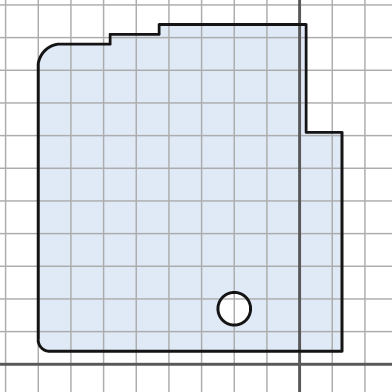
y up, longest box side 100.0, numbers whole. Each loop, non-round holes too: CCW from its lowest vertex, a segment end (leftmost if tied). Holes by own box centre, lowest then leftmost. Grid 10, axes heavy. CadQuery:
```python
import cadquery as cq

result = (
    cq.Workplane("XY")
    .moveTo(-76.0, 4.0)
    .lineTo(13.0, 4.0)
    .lineTo(13.0, 71.0)
    .lineTo(2.0, 71.0)
    .lineTo(2.0, 104.0)
    .lineTo(-43.0, 104.0)
    .lineTo(-43.0, 101.0)
    .lineTo(-58.0, 101.0)
    .lineTo(-58.0, 98.0)
    .lineTo(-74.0, 98.0)
    .threePointArc((-78.0, 96.0), (-80.0, 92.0))
    .lineTo(-80.0, 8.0)
    .threePointArc((-79.0, 5.0), (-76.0, 4.0))
    .close()
    .moveTo(-20.0, 17.0)
    .circle(5.0)
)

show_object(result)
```